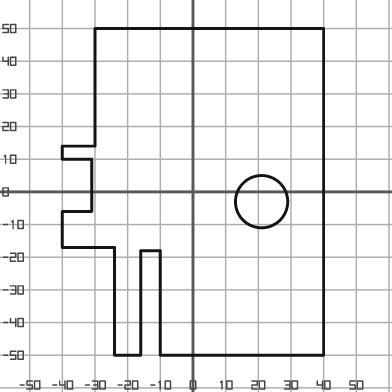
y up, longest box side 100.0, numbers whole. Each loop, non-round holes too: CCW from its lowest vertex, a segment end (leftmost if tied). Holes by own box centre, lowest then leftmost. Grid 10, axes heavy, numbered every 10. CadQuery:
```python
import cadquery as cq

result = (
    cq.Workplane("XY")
    .moveTo(-24.0, -50.0)
    .lineTo(-16.0, -50.0)
    .lineTo(-16.0, -18.0)
    .lineTo(-10.0, -18.0)
    .lineTo(-10.0, -50.0)
    .lineTo(40.0, -50.0)
    .lineTo(40.0, 50.0)
    .lineTo(-30.0, 50.0)
    .lineTo(-30.0, 14.0)
    .lineTo(-40.0, 14.0)
    .lineTo(-40.0, 10.0)
    .lineTo(-31.0, 10.0)
    .lineTo(-31.0, -6.0)
    .lineTo(-40.0, -6.0)
    .lineTo(-40.0, -17.0)
    .lineTo(-24.0, -17.0)
    .close()
    .moveTo(21.0, -3.0)
    .circle(8.0)
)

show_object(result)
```